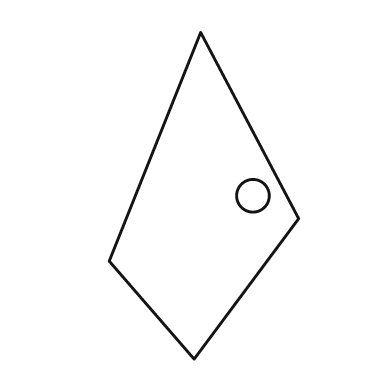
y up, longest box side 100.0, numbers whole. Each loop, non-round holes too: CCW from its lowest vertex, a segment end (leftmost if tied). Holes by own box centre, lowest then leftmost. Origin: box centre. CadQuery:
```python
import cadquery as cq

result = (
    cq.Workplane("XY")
    .moveTo(-3.0, -50.0)
    .lineTo(29.0, -7.0)
    .lineTo(-1.0, 50.0)
    .lineTo(-29.0, -20.0)
    .close()
    .moveTo(15.0, 0.0)
    .circle(5.0)
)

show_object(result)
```